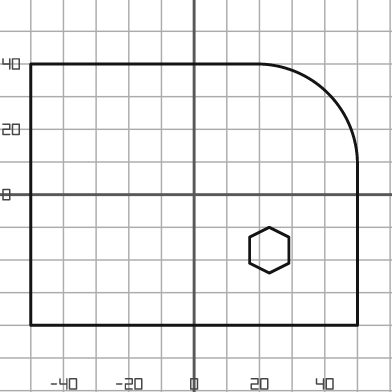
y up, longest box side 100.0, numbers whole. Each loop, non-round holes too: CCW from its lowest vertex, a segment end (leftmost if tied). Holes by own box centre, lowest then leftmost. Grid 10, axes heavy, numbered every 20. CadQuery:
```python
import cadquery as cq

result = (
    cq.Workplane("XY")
    .moveTo(-50.0, -40.0)
    .lineTo(50.0, -40.0)
    .lineTo(50.0, 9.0)
    .threePointArc((41.0, 31.0), (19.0, 40.0))
    .lineTo(-50.0, 40.0)
    .close()
    .moveTo(23.0, -24.0)
    .lineTo(29.0, -21.0)
    .lineTo(29.0, -13.0)
    .lineTo(23.0, -10.0)
    .lineTo(17.0, -13.0)
    .lineTo(17.0, -21.0)
    .close()
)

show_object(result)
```